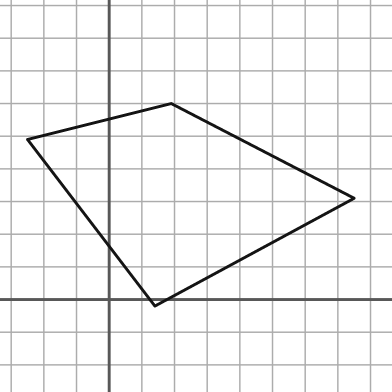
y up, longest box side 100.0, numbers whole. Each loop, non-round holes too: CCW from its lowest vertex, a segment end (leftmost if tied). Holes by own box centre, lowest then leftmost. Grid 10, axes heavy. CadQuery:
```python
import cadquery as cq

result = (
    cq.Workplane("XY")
    .moveTo(14.0, -2.0)
    .lineTo(75.0, 31.0)
    .lineTo(19.0, 60.0)
    .lineTo(-25.0, 49.0)
    .close()
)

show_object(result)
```